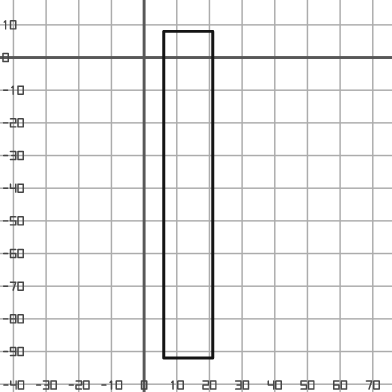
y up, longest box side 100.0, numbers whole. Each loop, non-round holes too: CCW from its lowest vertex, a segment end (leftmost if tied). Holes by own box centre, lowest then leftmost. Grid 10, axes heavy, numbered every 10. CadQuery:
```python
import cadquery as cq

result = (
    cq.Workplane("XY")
    .moveTo(6.0, -92.0)
    .lineTo(21.0, -92.0)
    .lineTo(21.0, 8.0)
    .lineTo(6.0, 8.0)
    .close()
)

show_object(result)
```